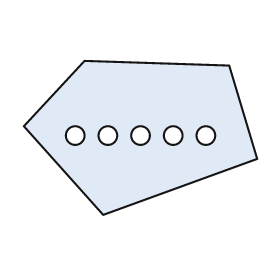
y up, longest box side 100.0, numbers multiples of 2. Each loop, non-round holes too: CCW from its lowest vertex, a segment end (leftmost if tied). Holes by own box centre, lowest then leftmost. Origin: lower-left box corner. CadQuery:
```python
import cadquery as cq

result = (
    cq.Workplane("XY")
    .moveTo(34.0, 0.0)
    .lineTo(100.0, 24.0)
    .lineTo(88.0, 64.0)
    .lineTo(26.0, 66.0)
    .lineTo(0.0, 38.0)
    .close()
    .moveTo(22.0, 34.0)
    .circle(4.0)
    .moveTo(36.0, 34.0)
    .circle(4.0)
    .moveTo(50.0, 34.0)
    .circle(4.0)
    .moveTo(64.0, 34.0)
    .circle(4.0)
    .moveTo(78.0, 34.0)
    .circle(4.0)
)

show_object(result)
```